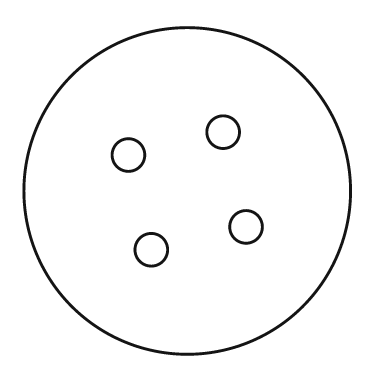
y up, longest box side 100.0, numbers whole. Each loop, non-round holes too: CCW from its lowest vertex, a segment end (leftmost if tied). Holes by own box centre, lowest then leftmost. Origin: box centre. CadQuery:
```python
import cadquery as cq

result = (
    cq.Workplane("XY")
    .moveTo(0.0, 0.0)
    .circle(50.0)
    .moveTo(-11.0, -18.0)
    .circle(5.0)
    .moveTo(18.0, -11.0)
    .circle(5.0)
    .moveTo(-18.0, 11.0)
    .circle(5.0)
    .moveTo(11.0, 18.0)
    .circle(5.0)
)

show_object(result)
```